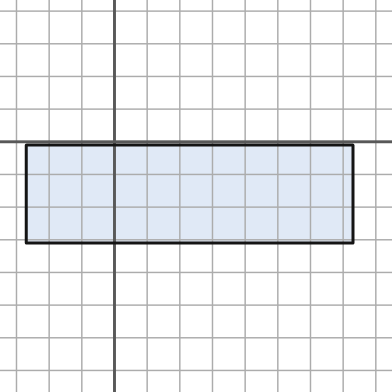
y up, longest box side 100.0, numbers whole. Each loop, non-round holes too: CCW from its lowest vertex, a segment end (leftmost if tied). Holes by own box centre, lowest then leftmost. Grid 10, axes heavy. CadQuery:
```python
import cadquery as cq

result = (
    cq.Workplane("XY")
    .moveTo(-27.0, -31.0)
    .lineTo(73.0, -31.0)
    .lineTo(73.0, -1.0)
    .lineTo(-27.0, -1.0)
    .close()
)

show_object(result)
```